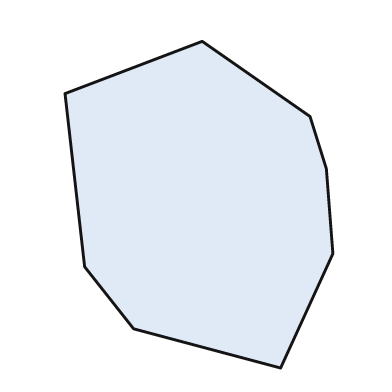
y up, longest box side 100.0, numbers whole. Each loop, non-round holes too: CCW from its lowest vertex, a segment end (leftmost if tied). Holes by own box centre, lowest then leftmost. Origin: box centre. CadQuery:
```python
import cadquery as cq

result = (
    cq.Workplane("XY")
    .moveTo(25.0, -50.0)
    .lineTo(41.0, -15.0)
    .lineTo(39.0, 11.0)
    .lineTo(34.0, 27.0)
    .lineTo(1.0, 50.0)
    .lineTo(-41.0, 34.0)
    .lineTo(-35.0, -19.0)
    .lineTo(-20.0, -38.0)
    .close()
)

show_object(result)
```